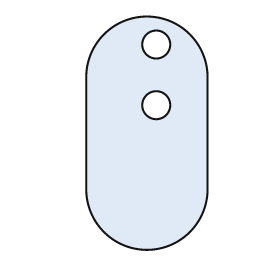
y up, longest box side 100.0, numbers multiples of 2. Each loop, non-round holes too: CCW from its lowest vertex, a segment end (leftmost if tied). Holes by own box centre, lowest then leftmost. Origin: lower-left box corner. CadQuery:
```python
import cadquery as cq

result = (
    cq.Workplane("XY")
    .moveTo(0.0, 26.0)
    .threePointArc((26.0, 0.0), (52.0, 26.0))
    .lineTo(52.0, 74.0)
    .threePointArc((26.0, 100.0), (0.0, 74.0))
    .close()
    .moveTo(30.0, 62.0)
    .circle(6.0)
    .moveTo(30.0, 88.0)
    .circle(6.0)
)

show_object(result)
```